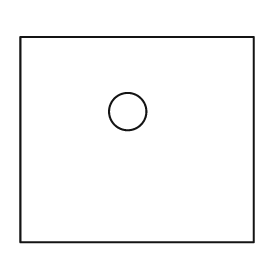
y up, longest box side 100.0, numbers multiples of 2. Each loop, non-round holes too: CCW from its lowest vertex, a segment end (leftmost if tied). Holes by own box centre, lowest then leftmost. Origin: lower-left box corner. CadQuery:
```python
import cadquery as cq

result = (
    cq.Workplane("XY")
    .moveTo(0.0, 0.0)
    .lineTo(100.0, 0.0)
    .lineTo(100.0, 88.0)
    .lineTo(0.0, 88.0)
    .close()
    .moveTo(46.0, 56.0)
    .circle(8.0)
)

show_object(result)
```